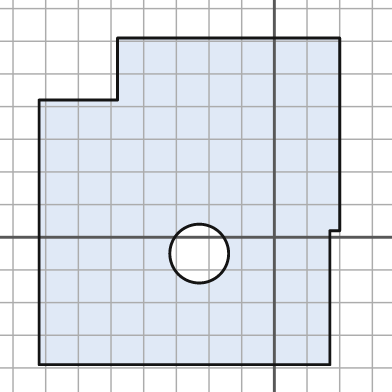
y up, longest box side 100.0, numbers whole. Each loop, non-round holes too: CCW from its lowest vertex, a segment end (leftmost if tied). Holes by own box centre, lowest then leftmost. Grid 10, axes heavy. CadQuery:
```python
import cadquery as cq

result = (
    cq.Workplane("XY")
    .moveTo(-72.0, -39.0)
    .lineTo(17.0, -39.0)
    .lineTo(17.0, 2.0)
    .lineTo(20.0, 2.0)
    .lineTo(20.0, 61.0)
    .lineTo(-48.0, 61.0)
    .lineTo(-48.0, 42.0)
    .lineTo(-72.0, 42.0)
    .close()
    .moveTo(-23.0, -5.0)
    .circle(9.0)
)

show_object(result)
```